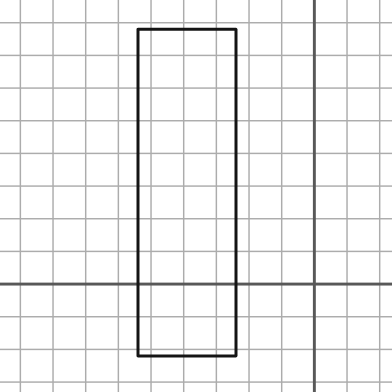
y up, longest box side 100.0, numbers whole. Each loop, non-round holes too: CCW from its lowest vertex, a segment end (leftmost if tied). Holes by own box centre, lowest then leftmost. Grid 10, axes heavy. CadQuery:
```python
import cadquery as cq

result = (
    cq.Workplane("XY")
    .moveTo(-54.0, -22.0)
    .lineTo(-24.0, -22.0)
    .lineTo(-24.0, 78.0)
    .lineTo(-54.0, 78.0)
    .close()
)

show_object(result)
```